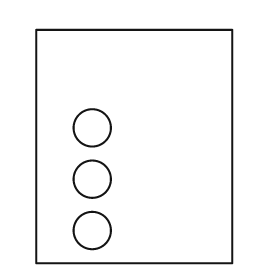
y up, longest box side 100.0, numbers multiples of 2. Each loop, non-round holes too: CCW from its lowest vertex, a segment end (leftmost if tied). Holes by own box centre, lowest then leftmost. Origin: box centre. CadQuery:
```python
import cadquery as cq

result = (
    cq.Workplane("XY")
    .moveTo(-42.0, -50.0)
    .lineTo(42.0, -50.0)
    .lineTo(42.0, 50.0)
    .lineTo(-42.0, 50.0)
    .close()
    .moveTo(-18.0, -36.0)
    .circle(8.0)
    .moveTo(-18.0, -14.0)
    .circle(8.0)
    .moveTo(-18.0, 8.0)
    .circle(8.0)
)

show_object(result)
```